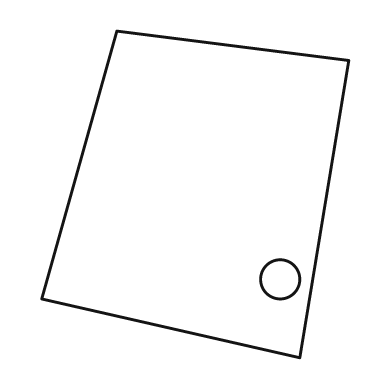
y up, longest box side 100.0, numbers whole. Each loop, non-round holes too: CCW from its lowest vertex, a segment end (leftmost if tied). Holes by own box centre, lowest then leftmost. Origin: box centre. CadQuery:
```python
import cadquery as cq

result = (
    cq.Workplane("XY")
    .moveTo(32.0, -50.0)
    .lineTo(47.0, 41.0)
    .lineTo(-24.0, 50.0)
    .lineTo(-47.0, -32.0)
    .close()
    .moveTo(26.0, -26.0)
    .circle(6.0)
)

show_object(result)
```